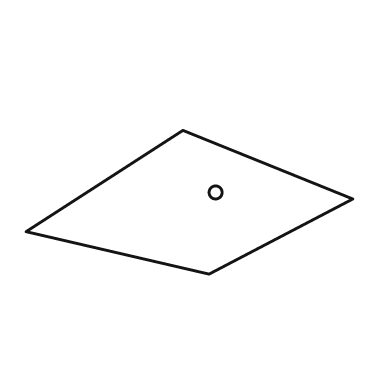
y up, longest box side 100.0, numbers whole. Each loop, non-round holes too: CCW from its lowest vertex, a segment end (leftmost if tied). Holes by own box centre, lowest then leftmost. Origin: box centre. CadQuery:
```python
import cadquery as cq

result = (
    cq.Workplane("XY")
    .moveTo(6.0, -22.0)
    .lineTo(50.0, 1.0)
    .lineTo(-2.0, 22.0)
    .lineTo(-50.0, -9.0)
    .close()
    .moveTo(8.0, 3.0)
    .circle(2.0)
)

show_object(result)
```